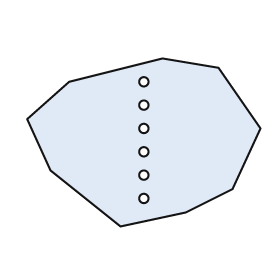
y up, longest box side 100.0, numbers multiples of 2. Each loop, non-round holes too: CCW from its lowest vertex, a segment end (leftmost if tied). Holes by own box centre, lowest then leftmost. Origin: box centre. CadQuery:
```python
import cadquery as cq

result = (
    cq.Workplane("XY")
    .moveTo(-10.0, -36.0)
    .lineTo(18.0, -30.0)
    .lineTo(38.0, -20.0)
    .lineTo(50.0, 6.0)
    .lineTo(32.0, 32.0)
    .lineTo(8.0, 36.0)
    .lineTo(-32.0, 26.0)
    .lineTo(-50.0, 10.0)
    .lineTo(-40.0, -12.0)
    .close()
    .moveTo(0.0, -24.0)
    .circle(2.0)
    .moveTo(0.0, -14.0)
    .circle(2.0)
    .moveTo(0.0, -4.0)
    .circle(2.0)
    .moveTo(0.0, 6.0)
    .circle(2.0)
    .moveTo(0.0, 16.0)
    .circle(2.0)
    .moveTo(0.0, 26.0)
    .circle(2.0)
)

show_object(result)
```